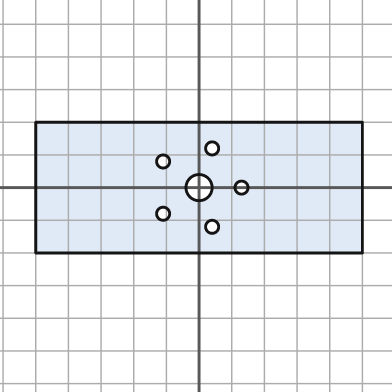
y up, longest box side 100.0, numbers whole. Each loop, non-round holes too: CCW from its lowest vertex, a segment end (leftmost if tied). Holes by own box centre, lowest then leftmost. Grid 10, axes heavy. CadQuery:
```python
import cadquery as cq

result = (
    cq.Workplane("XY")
    .moveTo(-50.0, -20.0)
    .lineTo(50.0, -20.0)
    .lineTo(50.0, 20.0)
    .lineTo(-50.0, 20.0)
    .close()
    .moveTo(4.0, -12.0)
    .circle(2.0)
    .moveTo(-11.0, -8.0)
    .circle(2.0)
    .moveTo(0.0, 0.0)
    .circle(4.0)
    .moveTo(13.0, 0.0)
    .circle(2.0)
    .moveTo(-11.0, 8.0)
    .circle(2.0)
    .moveTo(4.0, 12.0)
    .circle(2.0)
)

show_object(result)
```